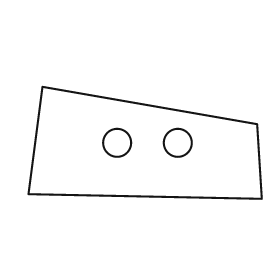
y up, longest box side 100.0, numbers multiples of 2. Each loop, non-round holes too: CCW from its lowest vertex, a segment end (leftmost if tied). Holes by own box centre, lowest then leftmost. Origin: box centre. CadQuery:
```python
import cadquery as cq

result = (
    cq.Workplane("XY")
    .moveTo(50.0, -24.0)
    .lineTo(48.0, 8.0)
    .lineTo(-44.0, 24.0)
    .lineTo(-50.0, -22.0)
    .close()
    .moveTo(-12.0, 0.0)
    .circle(6.0)
    .moveTo(14.0, 0.0)
    .circle(6.0)
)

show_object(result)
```